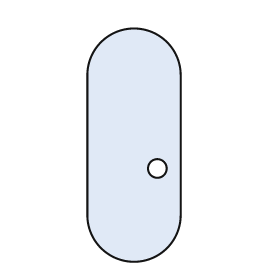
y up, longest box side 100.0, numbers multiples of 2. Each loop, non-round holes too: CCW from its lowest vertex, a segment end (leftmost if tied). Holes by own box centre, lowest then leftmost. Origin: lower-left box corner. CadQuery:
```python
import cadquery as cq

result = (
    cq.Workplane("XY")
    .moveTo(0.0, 20.0)
    .threePointArc((20.0, 0.0), (40.0, 20.0))
    .lineTo(40.0, 80.0)
    .threePointArc((20.0, 100.0), (0.0, 80.0))
    .close()
    .moveTo(30.0, 40.0)
    .circle(4.0)
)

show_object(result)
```